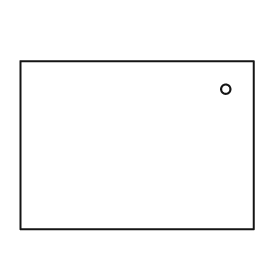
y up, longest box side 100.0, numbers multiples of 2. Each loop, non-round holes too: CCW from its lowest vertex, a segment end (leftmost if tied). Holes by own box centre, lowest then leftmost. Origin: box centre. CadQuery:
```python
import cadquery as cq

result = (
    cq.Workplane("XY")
    .moveTo(-50.0, -36.0)
    .lineTo(50.0, -36.0)
    .lineTo(50.0, 36.0)
    .lineTo(-50.0, 36.0)
    .close()
    .moveTo(38.0, 24.0)
    .circle(2.0)
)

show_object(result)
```